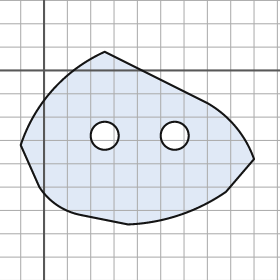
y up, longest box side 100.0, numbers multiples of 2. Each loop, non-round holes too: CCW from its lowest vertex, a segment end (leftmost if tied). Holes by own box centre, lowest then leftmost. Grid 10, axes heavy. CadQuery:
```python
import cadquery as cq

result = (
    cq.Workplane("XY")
    .moveTo(36.0, -66.0)
    .threePointArc((58.0, -62.0), (78.0, -52.0))
    .lineTo(90.0, -38.0)
    .threePointArc((82.0, -24.0), (70.0, -14.0))
    .lineTo(26.0, 8.0)
    .threePointArc((4.0, -8.0), (-10.0, -32.0))
    .lineTo(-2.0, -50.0)
    .threePointArc((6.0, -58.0), (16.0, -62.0))
    .close()
    .moveTo(26.0, -28.0)
    .circle(6.0)
    .moveTo(56.0, -28.0)
    .circle(6.0)
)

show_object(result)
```